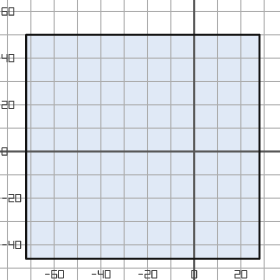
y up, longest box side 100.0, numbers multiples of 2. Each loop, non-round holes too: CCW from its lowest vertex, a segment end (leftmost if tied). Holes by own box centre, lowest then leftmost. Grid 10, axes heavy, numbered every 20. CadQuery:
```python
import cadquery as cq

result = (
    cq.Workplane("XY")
    .moveTo(-72.0, -46.0)
    .lineTo(28.0, -46.0)
    .lineTo(28.0, 50.0)
    .lineTo(-72.0, 50.0)
    .close()
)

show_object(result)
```